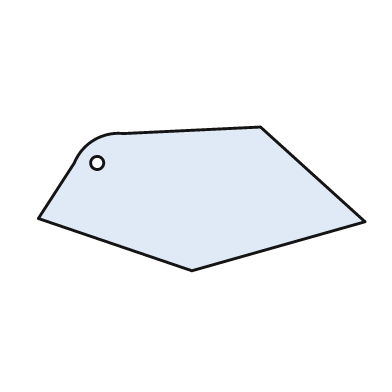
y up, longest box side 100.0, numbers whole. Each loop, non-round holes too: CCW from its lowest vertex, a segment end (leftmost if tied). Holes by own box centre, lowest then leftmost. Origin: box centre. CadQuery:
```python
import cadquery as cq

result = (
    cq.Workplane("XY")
    .moveTo(-3.0, -22.0)
    .lineTo(50.0, -7.0)
    .lineTo(18.0, 22.0)
    .lineTo(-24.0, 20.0)
    .threePointArc((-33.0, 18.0), (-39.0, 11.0))
    .lineTo(-50.0, -6.0)
    .close()
    .moveTo(-32.0, 11.0)
    .circle(2.0)
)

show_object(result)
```